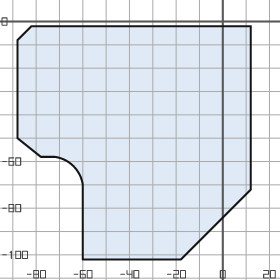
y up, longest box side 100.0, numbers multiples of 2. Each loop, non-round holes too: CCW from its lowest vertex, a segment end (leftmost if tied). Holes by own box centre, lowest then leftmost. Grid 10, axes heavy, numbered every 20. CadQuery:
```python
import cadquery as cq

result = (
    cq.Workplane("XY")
    .moveTo(-60.0, -102.0)
    .lineTo(-18.0, -102.0)
    .lineTo(12.0, -72.0)
    .lineTo(12.0, -2.0)
    .lineTo(-82.0, -2.0)
    .lineTo(-88.0, -8.0)
    .lineTo(-88.0, -50.0)
    .lineTo(-78.0, -58.0)
    .lineTo(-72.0, -58.0)
    .threePointArc((-64.0, -62.0), (-60.0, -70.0))
    .close()
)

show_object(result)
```